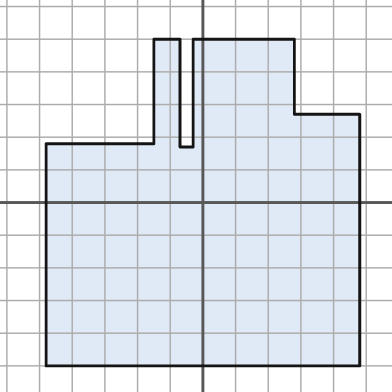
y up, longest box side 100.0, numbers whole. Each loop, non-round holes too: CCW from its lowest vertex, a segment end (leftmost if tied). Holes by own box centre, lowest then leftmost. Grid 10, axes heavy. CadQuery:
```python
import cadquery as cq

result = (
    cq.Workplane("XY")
    .moveTo(-48.0, -50.0)
    .lineTo(48.0, -50.0)
    .lineTo(48.0, 27.0)
    .lineTo(28.0, 27.0)
    .lineTo(28.0, 50.0)
    .lineTo(-3.0, 50.0)
    .lineTo(-3.0, 17.0)
    .lineTo(-7.0, 17.0)
    .lineTo(-7.0, 50.0)
    .lineTo(-15.0, 50.0)
    .lineTo(-15.0, 18.0)
    .lineTo(-48.0, 18.0)
    .close()
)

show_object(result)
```